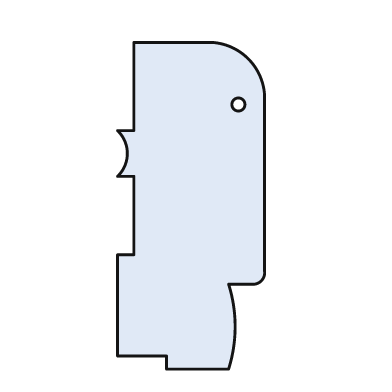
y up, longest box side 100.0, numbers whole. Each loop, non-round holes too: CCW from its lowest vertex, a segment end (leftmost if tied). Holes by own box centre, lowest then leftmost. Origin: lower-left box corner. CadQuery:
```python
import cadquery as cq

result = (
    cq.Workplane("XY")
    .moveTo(15.0, 0.0)
    .lineTo(34.0, 0.0)
    .threePointArc((36.0, 13.0), (34.0, 26.0))
    .lineTo(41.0, 26.0)
    .threePointArc((44.0, 27.0), (45.0, 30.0))
    .lineTo(45.0, 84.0)
    .threePointArc((40.0, 95.0), (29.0, 100.0))
    .lineTo(5.0, 100.0)
    .lineTo(5.0, 73.0)
    .lineTo(0.0, 73.0)
    .threePointArc((3.0, 66.0), (0.0, 59.0))
    .lineTo(5.0, 59.0)
    .lineTo(5.0, 35.0)
    .lineTo(0.0, 35.0)
    .lineTo(0.0, 4.0)
    .lineTo(15.0, 4.0)
    .close()
    .moveTo(37.0, 81.0)
    .circle(2.0)
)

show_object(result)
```